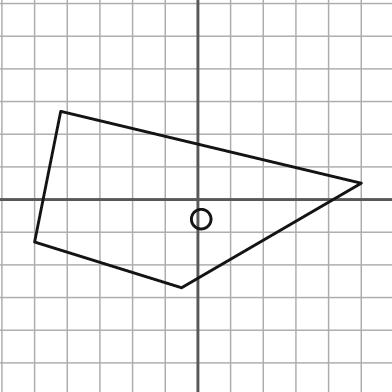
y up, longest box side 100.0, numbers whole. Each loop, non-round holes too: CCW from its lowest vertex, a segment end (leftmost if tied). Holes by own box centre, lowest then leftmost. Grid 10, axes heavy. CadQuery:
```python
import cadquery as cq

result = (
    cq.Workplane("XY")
    .moveTo(-5.0, -27.0)
    .lineTo(50.0, 5.0)
    .lineTo(-42.0, 27.0)
    .lineTo(-50.0, -13.0)
    .close()
    .moveTo(1.0, -6.0)
    .circle(3.0)
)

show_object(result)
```